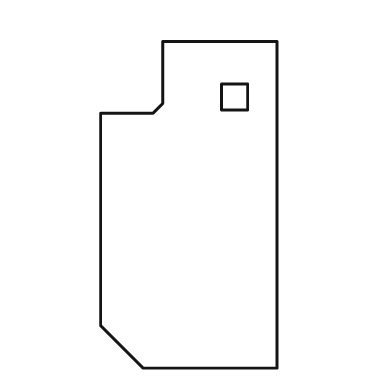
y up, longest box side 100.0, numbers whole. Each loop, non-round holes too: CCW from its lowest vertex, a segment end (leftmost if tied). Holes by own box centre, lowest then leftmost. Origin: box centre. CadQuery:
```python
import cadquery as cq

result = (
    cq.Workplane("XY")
    .moveTo(-14.0, -50.0)
    .lineTo(27.0, -50.0)
    .lineTo(27.0, 50.0)
    .lineTo(-8.0, 50.0)
    .lineTo(-8.0, 31.0)
    .lineTo(-11.0, 28.0)
    .lineTo(-27.0, 28.0)
    .lineTo(-27.0, -37.0)
    .close()
    .moveTo(10.0, 29.0)
    .lineTo(18.0, 29.0)
    .lineTo(18.0, 37.0)
    .lineTo(10.0, 37.0)
    .close()
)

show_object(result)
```